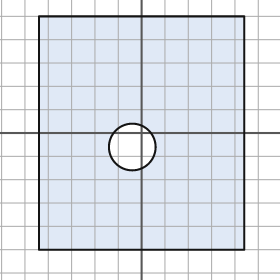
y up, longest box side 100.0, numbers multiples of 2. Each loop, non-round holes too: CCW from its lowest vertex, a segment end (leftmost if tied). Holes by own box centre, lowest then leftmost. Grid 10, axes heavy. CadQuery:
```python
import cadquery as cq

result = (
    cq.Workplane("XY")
    .moveTo(-44.0, -50.0)
    .lineTo(44.0, -50.0)
    .lineTo(44.0, 50.0)
    .lineTo(-44.0, 50.0)
    .close()
    .moveTo(-4.0, -6.0)
    .circle(10.0)
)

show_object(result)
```